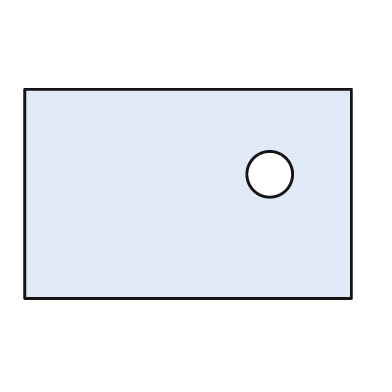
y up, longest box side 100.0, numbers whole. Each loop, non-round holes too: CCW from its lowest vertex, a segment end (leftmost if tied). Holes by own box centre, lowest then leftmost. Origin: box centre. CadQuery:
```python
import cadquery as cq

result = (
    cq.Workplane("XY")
    .moveTo(-50.0, -32.0)
    .lineTo(50.0, -32.0)
    .lineTo(50.0, 32.0)
    .lineTo(-50.0, 32.0)
    .close()
    .moveTo(25.0, 6.0)
    .circle(7.0)
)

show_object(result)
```